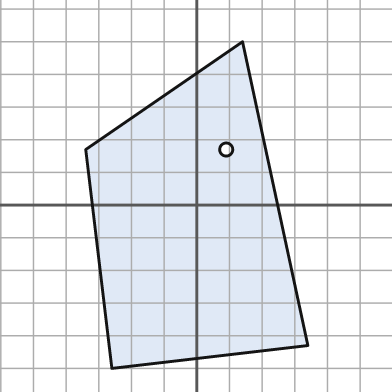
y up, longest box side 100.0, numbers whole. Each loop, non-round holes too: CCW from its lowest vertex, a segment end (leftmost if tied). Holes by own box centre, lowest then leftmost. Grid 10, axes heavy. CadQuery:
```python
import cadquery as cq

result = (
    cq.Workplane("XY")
    .moveTo(-26.0, -50.0)
    .lineTo(34.0, -43.0)
    .lineTo(14.0, 50.0)
    .lineTo(-34.0, 17.0)
    .close()
    .moveTo(9.0, 17.0)
    .circle(2.0)
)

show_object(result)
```